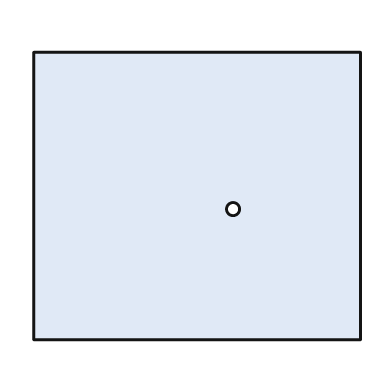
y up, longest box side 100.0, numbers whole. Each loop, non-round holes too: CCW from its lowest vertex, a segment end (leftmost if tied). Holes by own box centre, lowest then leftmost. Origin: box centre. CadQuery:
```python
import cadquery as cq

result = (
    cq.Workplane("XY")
    .moveTo(-50.0, -44.0)
    .lineTo(50.0, -44.0)
    .lineTo(50.0, 44.0)
    .lineTo(-50.0, 44.0)
    .close()
    .moveTo(11.0, -4.0)
    .circle(2.0)
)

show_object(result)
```